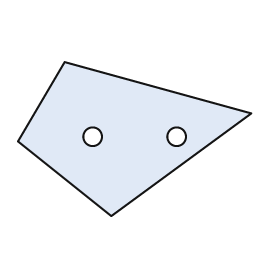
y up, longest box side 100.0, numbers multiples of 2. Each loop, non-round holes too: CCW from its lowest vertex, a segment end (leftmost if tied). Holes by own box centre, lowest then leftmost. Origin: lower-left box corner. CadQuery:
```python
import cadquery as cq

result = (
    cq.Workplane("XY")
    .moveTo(40.0, 0.0)
    .lineTo(100.0, 44.0)
    .lineTo(20.0, 66.0)
    .lineTo(0.0, 32.0)
    .close()
    .moveTo(32.0, 34.0)
    .circle(4.0)
    .moveTo(68.0, 34.0)
    .circle(4.0)
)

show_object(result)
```